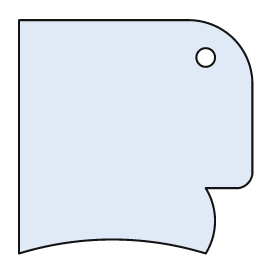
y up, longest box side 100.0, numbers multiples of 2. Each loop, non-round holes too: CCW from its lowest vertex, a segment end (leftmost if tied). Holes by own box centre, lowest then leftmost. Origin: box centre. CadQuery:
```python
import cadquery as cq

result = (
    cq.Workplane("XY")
    .moveTo(-50.0, -50.0)
    .threePointArc((-10.0, -44.0), (30.0, -50.0))
    .threePointArc((34.0, -36.0), (30.0, -22.0))
    .lineTo(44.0, -22.0)
    .threePointArc((48.0, -20.0), (50.0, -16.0))
    .lineTo(50.0, 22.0)
    .threePointArc((42.0, 42.0), (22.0, 50.0))
    .lineTo(-50.0, 50.0)
    .close()
    .moveTo(30.0, 34.0)
    .circle(4.0)
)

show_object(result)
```